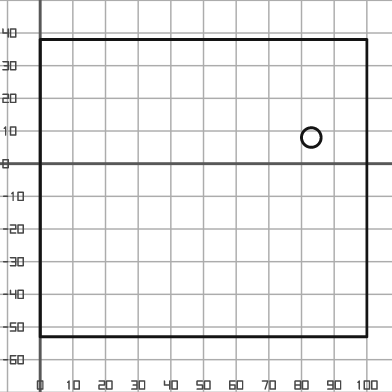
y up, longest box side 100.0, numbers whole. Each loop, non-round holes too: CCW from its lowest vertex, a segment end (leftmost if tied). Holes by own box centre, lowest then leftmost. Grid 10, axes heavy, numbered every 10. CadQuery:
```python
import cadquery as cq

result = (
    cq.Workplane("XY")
    .moveTo(0.0, -53.0)
    .lineTo(100.0, -53.0)
    .lineTo(100.0, 38.0)
    .lineTo(0.0, 38.0)
    .close()
    .moveTo(83.0, 8.0)
    .circle(3.0)
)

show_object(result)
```